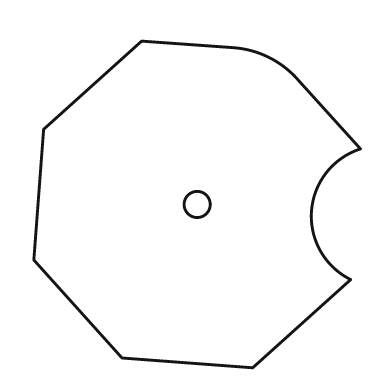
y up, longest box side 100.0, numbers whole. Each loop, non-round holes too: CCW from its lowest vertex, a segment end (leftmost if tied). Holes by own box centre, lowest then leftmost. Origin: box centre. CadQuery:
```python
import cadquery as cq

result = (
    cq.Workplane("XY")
    .moveTo(17.0, -50.0)
    .lineTo(47.0, -23.0)
    .threePointArc((35.0, -2.0), (50.0, 17.0))
    .lineTo(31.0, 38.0)
    .threePointArc((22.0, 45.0), (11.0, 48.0))
    .lineTo(-17.0, 50.0)
    .lineTo(-47.0, 23.0)
    .lineTo(-50.0, -17.0)
    .lineTo(-23.0, -47.0)
    .close()
    .moveTo(0.0, 0.0)
    .circle(4.0)
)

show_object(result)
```